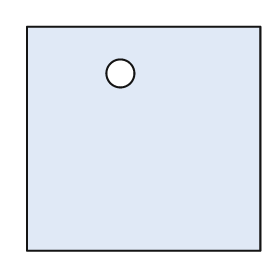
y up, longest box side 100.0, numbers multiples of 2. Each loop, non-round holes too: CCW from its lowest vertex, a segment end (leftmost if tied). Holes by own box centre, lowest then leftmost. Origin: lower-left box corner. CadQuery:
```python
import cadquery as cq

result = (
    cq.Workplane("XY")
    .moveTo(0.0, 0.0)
    .lineTo(100.0, 0.0)
    .lineTo(100.0, 96.0)
    .lineTo(0.0, 96.0)
    .close()
    .moveTo(40.0, 76.0)
    .circle(6.0)
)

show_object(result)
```